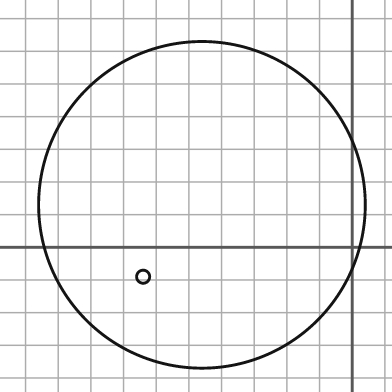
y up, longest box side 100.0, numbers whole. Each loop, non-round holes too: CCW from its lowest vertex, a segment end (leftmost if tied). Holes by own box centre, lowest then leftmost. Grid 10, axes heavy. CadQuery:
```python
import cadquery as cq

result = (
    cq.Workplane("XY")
    .moveTo(-46.0, 13.0)
    .circle(50.0)
    .moveTo(-64.0, -9.0)
    .circle(2.0)
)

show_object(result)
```